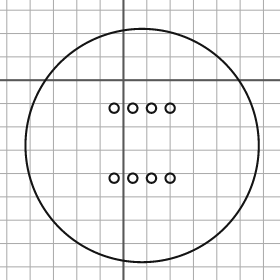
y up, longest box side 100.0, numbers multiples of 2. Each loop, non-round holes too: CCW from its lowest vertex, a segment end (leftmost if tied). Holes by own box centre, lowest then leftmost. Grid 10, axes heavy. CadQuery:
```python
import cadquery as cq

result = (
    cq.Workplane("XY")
    .moveTo(8.0, -28.0)
    .circle(50.0)
    .moveTo(-4.0, -42.0)
    .circle(2.0)
    .moveTo(4.0, -42.0)
    .circle(2.0)
    .moveTo(12.0, -42.0)
    .circle(2.0)
    .moveTo(20.0, -42.0)
    .circle(2.0)
    .moveTo(-4.0, -12.0)
    .circle(2.0)
    .moveTo(4.0, -12.0)
    .circle(2.0)
    .moveTo(12.0, -12.0)
    .circle(2.0)
    .moveTo(20.0, -12.0)
    .circle(2.0)
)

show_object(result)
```